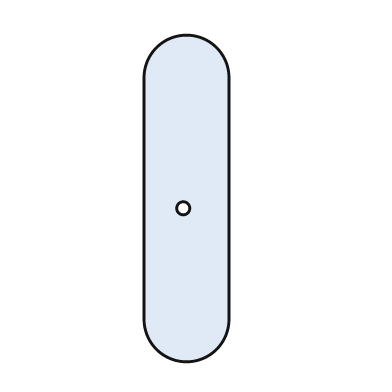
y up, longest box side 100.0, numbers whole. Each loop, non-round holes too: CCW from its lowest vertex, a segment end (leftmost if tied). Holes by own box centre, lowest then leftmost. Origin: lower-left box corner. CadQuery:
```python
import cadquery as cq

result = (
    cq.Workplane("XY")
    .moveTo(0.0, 13.0)
    .threePointArc((13.0, 0.0), (26.0, 13.0))
    .lineTo(26.0, 87.0)
    .threePointArc((13.0, 100.0), (0.0, 87.0))
    .close()
    .moveTo(12.0, 47.0)
    .circle(2.0)
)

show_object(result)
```